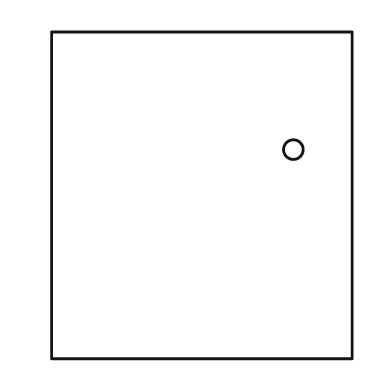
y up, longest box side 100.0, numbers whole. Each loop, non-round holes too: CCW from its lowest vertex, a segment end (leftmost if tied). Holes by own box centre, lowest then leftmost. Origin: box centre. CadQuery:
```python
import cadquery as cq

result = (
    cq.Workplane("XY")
    .moveTo(-46.0, -50.0)
    .lineTo(46.0, -50.0)
    .lineTo(46.0, 50.0)
    .lineTo(-46.0, 50.0)
    .close()
    .moveTo(28.0, 14.0)
    .circle(3.0)
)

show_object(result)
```